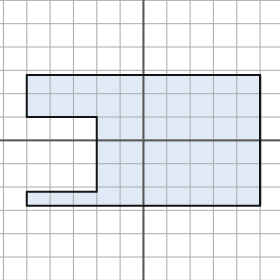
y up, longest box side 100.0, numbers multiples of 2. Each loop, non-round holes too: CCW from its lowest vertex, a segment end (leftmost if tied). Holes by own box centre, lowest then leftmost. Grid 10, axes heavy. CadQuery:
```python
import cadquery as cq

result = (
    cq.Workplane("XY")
    .moveTo(-50.0, -28.0)
    .lineTo(50.0, -28.0)
    .lineTo(50.0, 28.0)
    .lineTo(-50.0, 28.0)
    .lineTo(-50.0, 10.0)
    .lineTo(-20.0, 10.0)
    .lineTo(-20.0, -22.0)
    .lineTo(-50.0, -22.0)
    .close()
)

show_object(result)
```